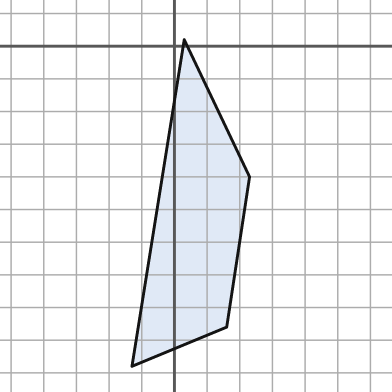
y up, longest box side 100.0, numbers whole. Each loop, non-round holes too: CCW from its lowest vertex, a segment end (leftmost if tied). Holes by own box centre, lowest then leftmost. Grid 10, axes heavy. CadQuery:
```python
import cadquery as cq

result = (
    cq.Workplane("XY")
    .moveTo(-13.0, -98.0)
    .lineTo(16.0, -86.0)
    .lineTo(23.0, -40.0)
    .lineTo(3.0, 2.0)
    .close()
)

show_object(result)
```